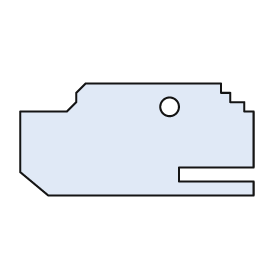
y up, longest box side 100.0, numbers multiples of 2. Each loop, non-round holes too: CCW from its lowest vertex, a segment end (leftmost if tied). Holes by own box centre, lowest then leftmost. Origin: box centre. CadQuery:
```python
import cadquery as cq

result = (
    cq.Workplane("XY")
    .moveTo(-38.0, -24.0)
    .lineTo(50.0, -24.0)
    .lineTo(50.0, -18.0)
    .lineTo(18.0, -18.0)
    .lineTo(18.0, -12.0)
    .lineTo(50.0, -12.0)
    .lineTo(50.0, 12.0)
    .lineTo(46.0, 12.0)
    .lineTo(46.0, 16.0)
    .lineTo(40.0, 16.0)
    .lineTo(40.0, 20.0)
    .lineTo(36.0, 20.0)
    .lineTo(36.0, 24.0)
    .lineTo(-22.0, 24.0)
    .lineTo(-26.0, 20.0)
    .lineTo(-26.0, 16.0)
    .lineTo(-30.0, 12.0)
    .lineTo(-50.0, 12.0)
    .lineTo(-50.0, -14.0)
    .close()
    .moveTo(14.0, 14.0)
    .circle(4.0)
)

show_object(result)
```